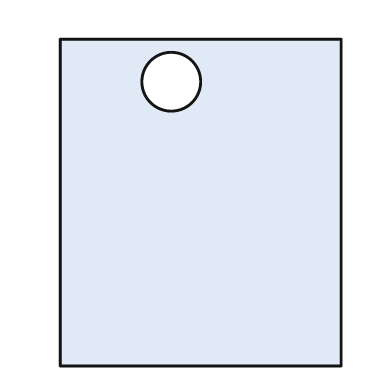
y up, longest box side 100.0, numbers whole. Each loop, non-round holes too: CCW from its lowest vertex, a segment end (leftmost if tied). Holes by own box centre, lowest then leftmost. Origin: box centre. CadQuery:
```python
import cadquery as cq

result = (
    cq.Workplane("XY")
    .moveTo(-43.0, -50.0)
    .lineTo(43.0, -50.0)
    .lineTo(43.0, 50.0)
    .lineTo(-43.0, 50.0)
    .close()
    .moveTo(-9.0, 37.0)
    .circle(9.0)
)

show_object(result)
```